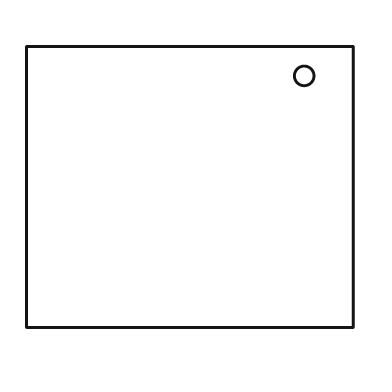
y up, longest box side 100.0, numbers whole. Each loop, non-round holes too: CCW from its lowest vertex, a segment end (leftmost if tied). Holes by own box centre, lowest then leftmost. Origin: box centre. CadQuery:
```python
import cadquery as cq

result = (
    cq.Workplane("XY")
    .moveTo(-50.0, -43.0)
    .lineTo(50.0, -43.0)
    .lineTo(50.0, 43.0)
    .lineTo(-50.0, 43.0)
    .close()
    .moveTo(35.0, 34.0)
    .circle(3.0)
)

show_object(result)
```